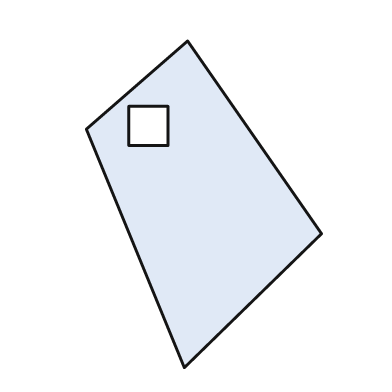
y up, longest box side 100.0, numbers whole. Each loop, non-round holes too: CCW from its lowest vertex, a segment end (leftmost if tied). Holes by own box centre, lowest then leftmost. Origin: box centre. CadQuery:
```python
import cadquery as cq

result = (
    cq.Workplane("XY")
    .moveTo(-6.0, -50.0)
    .lineTo(36.0, -9.0)
    .lineTo(-5.0, 50.0)
    .lineTo(-36.0, 23.0)
    .close()
    .moveTo(-23.0, 18.0)
    .lineTo(-11.0, 18.0)
    .lineTo(-11.0, 30.0)
    .lineTo(-23.0, 30.0)
    .close()
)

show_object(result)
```